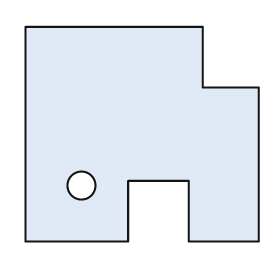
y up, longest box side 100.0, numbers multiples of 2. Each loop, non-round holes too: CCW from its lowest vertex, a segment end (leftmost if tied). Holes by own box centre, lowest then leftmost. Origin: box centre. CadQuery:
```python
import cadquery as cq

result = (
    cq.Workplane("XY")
    .moveTo(-50.0, -46.0)
    .lineTo(-6.0, -46.0)
    .lineTo(-6.0, -20.0)
    .lineTo(20.0, -20.0)
    .lineTo(20.0, -46.0)
    .lineTo(50.0, -46.0)
    .lineTo(50.0, 20.0)
    .lineTo(26.0, 20.0)
    .lineTo(26.0, 46.0)
    .lineTo(-50.0, 46.0)
    .close()
    .moveTo(-26.0, -22.0)
    .circle(6.0)
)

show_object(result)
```